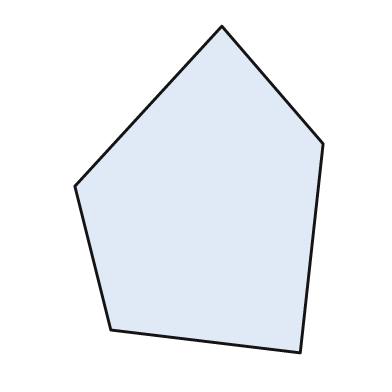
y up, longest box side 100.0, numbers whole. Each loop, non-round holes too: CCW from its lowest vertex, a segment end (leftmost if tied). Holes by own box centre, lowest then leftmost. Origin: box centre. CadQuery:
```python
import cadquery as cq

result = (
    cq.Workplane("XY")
    .moveTo(31.0, -50.0)
    .lineTo(38.0, 14.0)
    .lineTo(7.0, 50.0)
    .lineTo(-38.0, 1.0)
    .lineTo(-27.0, -43.0)
    .close()
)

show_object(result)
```